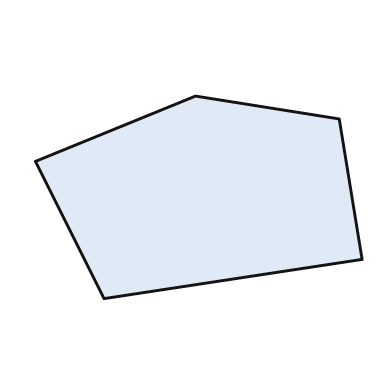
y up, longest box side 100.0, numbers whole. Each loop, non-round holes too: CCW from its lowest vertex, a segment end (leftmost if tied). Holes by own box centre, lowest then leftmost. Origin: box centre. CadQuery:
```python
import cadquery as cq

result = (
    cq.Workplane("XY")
    .moveTo(-29.0, -31.0)
    .lineTo(50.0, -19.0)
    .lineTo(43.0, 24.0)
    .lineTo(-1.0, 31.0)
    .lineTo(-50.0, 11.0)
    .close()
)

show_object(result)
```